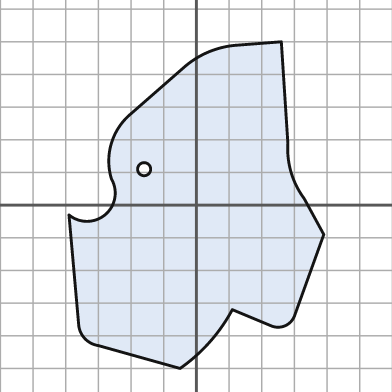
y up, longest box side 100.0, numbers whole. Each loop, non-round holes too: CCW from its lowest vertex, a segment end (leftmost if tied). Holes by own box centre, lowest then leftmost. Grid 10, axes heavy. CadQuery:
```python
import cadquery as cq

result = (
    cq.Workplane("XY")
    .moveTo(-5.0, -50.0)
    .threePointArc((4.0, -42.0), (11.0, -32.0))
    .lineTo(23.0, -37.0)
    .threePointArc((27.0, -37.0), (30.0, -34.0))
    .lineTo(39.0, -9.0)
    .lineTo(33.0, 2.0)
    .threePointArc((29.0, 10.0), (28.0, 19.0))
    .lineTo(26.0, 50.0)
    .lineTo(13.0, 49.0)
    .threePointArc((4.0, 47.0), (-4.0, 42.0))
    .lineTo(-20.0, 28.0)
    .threePointArc((-26.0, 19.0), (-26.0, 8.0))
    .threePointArc((-28.0, -3.0), (-39.0, -3.0))
    .lineTo(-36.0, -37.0)
    .threePointArc((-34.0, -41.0), (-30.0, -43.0))
    .close()
    .moveTo(-16.0, 11.0)
    .circle(2.0)
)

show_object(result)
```